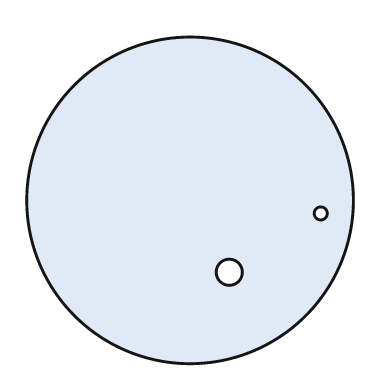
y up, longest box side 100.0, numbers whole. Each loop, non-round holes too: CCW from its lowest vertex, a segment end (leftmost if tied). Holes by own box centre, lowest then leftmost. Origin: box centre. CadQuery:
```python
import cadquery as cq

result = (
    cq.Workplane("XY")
    .moveTo(0.0, 0.0)
    .circle(50.0)
    .moveTo(12.0, -22.0)
    .circle(4.0)
    .moveTo(40.0, -4.0)
    .circle(2.0)
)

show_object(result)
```